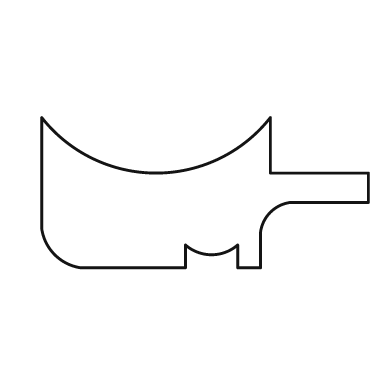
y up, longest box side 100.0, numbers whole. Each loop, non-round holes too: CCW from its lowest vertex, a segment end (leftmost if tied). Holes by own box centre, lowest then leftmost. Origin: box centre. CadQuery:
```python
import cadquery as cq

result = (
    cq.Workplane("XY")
    .moveTo(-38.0, -23.0)
    .lineTo(-6.0, -23.0)
    .lineTo(-6.0, -16.0)
    .threePointArc((2.0, -19.0), (10.0, -16.0))
    .lineTo(10.0, -23.0)
    .lineTo(17.0, -23.0)
    .lineTo(17.0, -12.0)
    .threePointArc((20.0, -6.0), (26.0, -3.0))
    .lineTo(50.0, -3.0)
    .lineTo(50.0, 6.0)
    .lineTo(20.0, 6.0)
    .lineTo(20.0, 23.0)
    .threePointArc((-15.0, 6.0), (-50.0, 23.0))
    .lineTo(-50.0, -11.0)
    .threePointArc((-46.0, -19.0), (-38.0, -23.0))
    .close()
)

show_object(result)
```